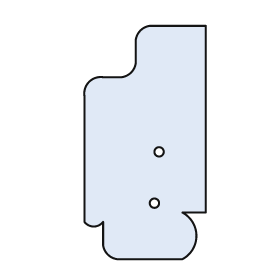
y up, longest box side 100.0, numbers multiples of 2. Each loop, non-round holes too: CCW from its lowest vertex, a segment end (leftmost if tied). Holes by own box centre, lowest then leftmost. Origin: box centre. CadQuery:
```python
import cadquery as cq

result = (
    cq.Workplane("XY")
    .moveTo(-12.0, -50.0)
    .lineTo(16.0, -50.0)
    .threePointArc((22.0, -40.0), (16.0, -30.0))
    .lineTo(26.0, -30.0)
    .lineTo(26.0, 50.0)
    .lineTo(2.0, 50.0)
    .threePointArc((-2.0, 48.0), (-4.0, 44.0))
    .lineTo(-4.0, 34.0)
    .threePointArc((-6.0, 30.0), (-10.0, 28.0))
    .lineTo(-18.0, 28.0)
    .threePointArc((-24.0, 26.0), (-26.0, 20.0))
    .lineTo(-26.0, -34.0)
    .threePointArc((-22.0, -36.0), (-18.0, -34.0))
    .lineTo(-18.0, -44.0)
    .threePointArc((-16.0, -48.0), (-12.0, -50.0))
    .close()
    .moveTo(4.0, -26.0)
    .circle(2.0)
    .moveTo(6.0, -4.0)
    .circle(2.0)
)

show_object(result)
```